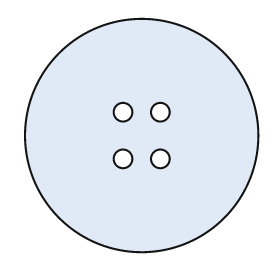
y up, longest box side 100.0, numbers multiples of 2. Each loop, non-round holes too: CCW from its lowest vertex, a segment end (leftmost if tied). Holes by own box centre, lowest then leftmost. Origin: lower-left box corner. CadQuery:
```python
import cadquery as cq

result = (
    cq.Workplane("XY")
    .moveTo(50.0, 50.0)
    .circle(50.0)
    .moveTo(42.0, 40.0)
    .circle(4.0)
    .moveTo(58.0, 40.0)
    .circle(4.0)
    .moveTo(42.0, 60.0)
    .circle(4.0)
    .moveTo(58.0, 60.0)
    .circle(4.0)
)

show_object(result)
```